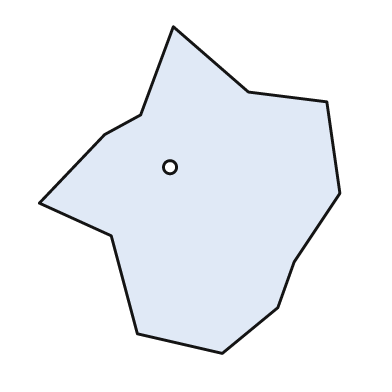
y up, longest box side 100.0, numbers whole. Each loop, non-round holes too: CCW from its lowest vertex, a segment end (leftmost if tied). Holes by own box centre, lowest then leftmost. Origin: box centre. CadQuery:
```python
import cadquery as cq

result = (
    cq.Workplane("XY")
    .moveTo(10.0, -50.0)
    .lineTo(27.0, -36.0)
    .lineTo(32.0, -22.0)
    .lineTo(46.0, -1.0)
    .lineTo(42.0, 27.0)
    .lineTo(18.0, 30.0)
    .lineTo(-5.0, 50.0)
    .lineTo(-15.0, 23.0)
    .lineTo(-26.0, 17.0)
    .lineTo(-46.0, -4.0)
    .lineTo(-24.0, -14.0)
    .lineTo(-16.0, -44.0)
    .close()
    .moveTo(-6.0, 7.0)
    .circle(2.0)
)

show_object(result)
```